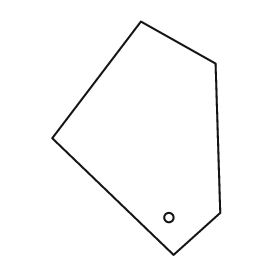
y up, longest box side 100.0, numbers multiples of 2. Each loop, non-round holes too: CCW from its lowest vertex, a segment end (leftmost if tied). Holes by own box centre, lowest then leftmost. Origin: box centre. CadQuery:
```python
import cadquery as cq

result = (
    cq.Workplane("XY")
    .moveTo(16.0, -50.0)
    .lineTo(36.0, -32.0)
    .lineTo(34.0, 32.0)
    .lineTo(2.0, 50.0)
    .lineTo(-36.0, 0.0)
    .close()
    .moveTo(14.0, -34.0)
    .circle(2.0)
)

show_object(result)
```